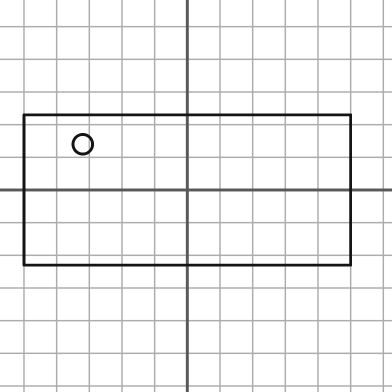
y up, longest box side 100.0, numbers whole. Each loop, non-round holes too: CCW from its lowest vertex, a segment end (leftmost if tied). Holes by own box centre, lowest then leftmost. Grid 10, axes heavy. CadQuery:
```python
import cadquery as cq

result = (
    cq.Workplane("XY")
    .moveTo(-50.0, -23.0)
    .lineTo(50.0, -23.0)
    .lineTo(50.0, 23.0)
    .lineTo(-50.0, 23.0)
    .close()
    .moveTo(-32.0, 14.0)
    .circle(3.0)
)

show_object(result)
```